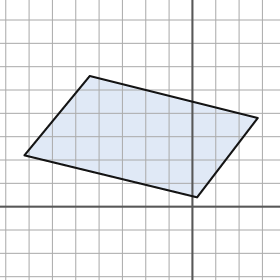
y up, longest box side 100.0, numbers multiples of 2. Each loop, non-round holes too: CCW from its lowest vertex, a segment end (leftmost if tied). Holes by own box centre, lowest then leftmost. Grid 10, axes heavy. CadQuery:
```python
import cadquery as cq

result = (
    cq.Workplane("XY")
    .moveTo(2.0, 4.0)
    .lineTo(28.0, 38.0)
    .lineTo(-44.0, 56.0)
    .lineTo(-72.0, 22.0)
    .close()
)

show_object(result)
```